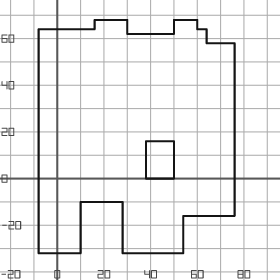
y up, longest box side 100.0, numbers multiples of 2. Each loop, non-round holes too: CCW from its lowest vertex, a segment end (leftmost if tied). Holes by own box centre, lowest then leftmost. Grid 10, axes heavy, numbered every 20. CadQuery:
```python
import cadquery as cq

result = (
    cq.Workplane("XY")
    .moveTo(-8.0, -32.0)
    .lineTo(10.0, -32.0)
    .lineTo(10.0, -10.0)
    .lineTo(28.0, -10.0)
    .lineTo(28.0, -32.0)
    .lineTo(54.0, -32.0)
    .lineTo(54.0, -16.0)
    .lineTo(76.0, -16.0)
    .lineTo(76.0, 58.0)
    .lineTo(64.0, 58.0)
    .lineTo(64.0, 64.0)
    .lineTo(60.0, 64.0)
    .lineTo(60.0, 68.0)
    .lineTo(50.0, 68.0)
    .lineTo(50.0, 62.0)
    .lineTo(30.0, 62.0)
    .lineTo(30.0, 68.0)
    .lineTo(16.0, 68.0)
    .lineTo(16.0, 64.0)
    .lineTo(-8.0, 64.0)
    .close()
    .moveTo(38.0, 0.0)
    .lineTo(50.0, 0.0)
    .lineTo(50.0, 16.0)
    .lineTo(38.0, 16.0)
    .close()
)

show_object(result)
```